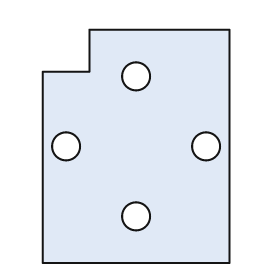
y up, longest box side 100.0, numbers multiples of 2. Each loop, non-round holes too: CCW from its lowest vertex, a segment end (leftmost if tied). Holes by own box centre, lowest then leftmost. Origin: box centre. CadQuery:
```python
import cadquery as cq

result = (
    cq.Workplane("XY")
    .moveTo(-40.0, -50.0)
    .lineTo(40.0, -50.0)
    .lineTo(40.0, 50.0)
    .lineTo(-20.0, 50.0)
    .lineTo(-20.0, 32.0)
    .lineTo(-40.0, 32.0)
    .close()
    .moveTo(0.0, -30.0)
    .circle(6.0)
    .moveTo(-30.0, 0.0)
    .circle(6.0)
    .moveTo(30.0, 0.0)
    .circle(6.0)
    .moveTo(0.0, 30.0)
    .circle(6.0)
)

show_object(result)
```